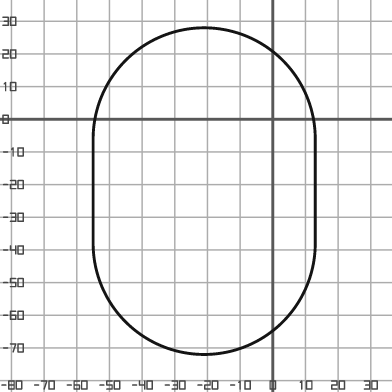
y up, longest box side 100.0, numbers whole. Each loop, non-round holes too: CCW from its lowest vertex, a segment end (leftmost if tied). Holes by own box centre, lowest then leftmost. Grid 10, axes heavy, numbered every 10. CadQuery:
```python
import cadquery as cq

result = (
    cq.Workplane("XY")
    .moveTo(-55.0, -38.0)
    .threePointArc((-21.0, -72.0), (13.0, -38.0))
    .lineTo(13.0, -6.0)
    .threePointArc((-21.0, 28.0), (-55.0, -6.0))
    .close()
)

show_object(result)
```